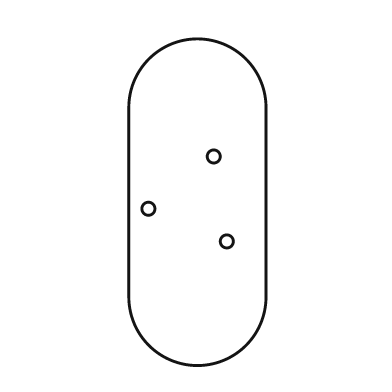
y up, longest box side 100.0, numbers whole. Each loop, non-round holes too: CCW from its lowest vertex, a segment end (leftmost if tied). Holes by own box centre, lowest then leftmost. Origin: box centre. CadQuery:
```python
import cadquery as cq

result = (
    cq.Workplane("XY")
    .moveTo(-21.0, -29.0)
    .threePointArc((0.0, -50.0), (21.0, -29.0))
    .lineTo(21.0, 29.0)
    .threePointArc((0.0, 50.0), (-21.0, 29.0))
    .close()
    .moveTo(9.0, -12.0)
    .circle(2.0)
    .moveTo(-15.0, -2.0)
    .circle(2.0)
    .moveTo(5.0, 14.0)
    .circle(2.0)
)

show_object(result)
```